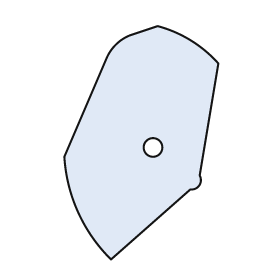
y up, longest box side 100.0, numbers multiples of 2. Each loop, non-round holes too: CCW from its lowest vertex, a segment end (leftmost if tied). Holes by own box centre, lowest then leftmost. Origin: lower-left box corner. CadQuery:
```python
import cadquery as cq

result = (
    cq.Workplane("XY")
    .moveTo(20.0, 0.0)
    .lineTo(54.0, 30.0)
    .threePointArc((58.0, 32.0), (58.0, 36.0))
    .lineTo(66.0, 84.0)
    .threePointArc((54.0, 94.0), (40.0, 100.0))
    .lineTo(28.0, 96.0)
    .threePointArc((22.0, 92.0), (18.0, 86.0))
    .lineTo(0.0, 44.0)
    .threePointArc((6.0, 20.0), (20.0, 0.0))
    .close()
    .moveTo(38.0, 48.0)
    .circle(4.0)
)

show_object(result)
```